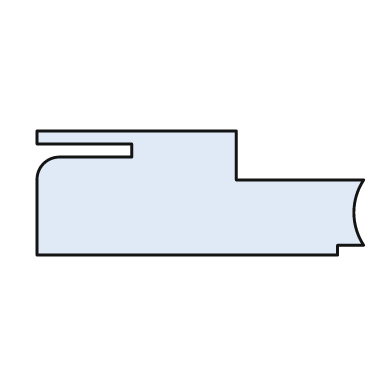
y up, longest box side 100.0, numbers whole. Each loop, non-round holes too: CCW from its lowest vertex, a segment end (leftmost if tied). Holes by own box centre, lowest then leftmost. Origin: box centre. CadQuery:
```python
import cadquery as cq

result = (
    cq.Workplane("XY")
    .moveTo(-50.0, -19.0)
    .lineTo(42.0, -19.0)
    .lineTo(42.0, -16.0)
    .lineTo(50.0, -16.0)
    .threePointArc((47.0, -6.0), (50.0, 4.0))
    .lineTo(11.0, 4.0)
    .lineTo(11.0, 19.0)
    .lineTo(-50.0, 19.0)
    .lineTo(-50.0, 15.0)
    .lineTo(-21.0, 15.0)
    .lineTo(-21.0, 11.0)
    .lineTo(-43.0, 11.0)
    .threePointArc((-48.0, 9.0), (-50.0, 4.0))
    .close()
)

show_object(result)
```